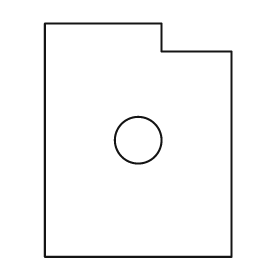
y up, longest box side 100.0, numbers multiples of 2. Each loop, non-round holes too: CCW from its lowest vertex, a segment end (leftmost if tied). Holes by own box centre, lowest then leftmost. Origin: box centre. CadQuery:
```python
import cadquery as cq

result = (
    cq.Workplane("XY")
    .moveTo(-40.0, -50.0)
    .lineTo(40.0, -50.0)
    .lineTo(40.0, 38.0)
    .lineTo(10.0, 38.0)
    .lineTo(10.0, 50.0)
    .lineTo(-40.0, 50.0)
    .close()
    .moveTo(0.0, 0.0)
    .circle(10.0)
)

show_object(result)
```